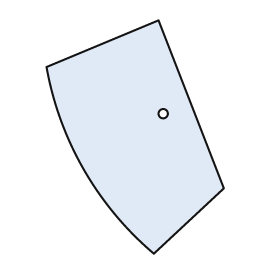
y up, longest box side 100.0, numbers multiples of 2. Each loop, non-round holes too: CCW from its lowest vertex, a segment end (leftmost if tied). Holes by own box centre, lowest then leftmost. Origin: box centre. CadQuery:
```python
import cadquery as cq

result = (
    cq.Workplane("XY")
    .moveTo(8.0, -50.0)
    .lineTo(38.0, -22.0)
    .lineTo(10.0, 50.0)
    .lineTo(-38.0, 30.0)
    .threePointArc((-22.0, -14.0), (8.0, -50.0))
    .close()
    .moveTo(12.0, 10.0)
    .circle(2.0)
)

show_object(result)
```